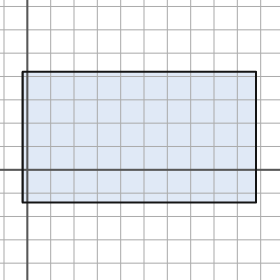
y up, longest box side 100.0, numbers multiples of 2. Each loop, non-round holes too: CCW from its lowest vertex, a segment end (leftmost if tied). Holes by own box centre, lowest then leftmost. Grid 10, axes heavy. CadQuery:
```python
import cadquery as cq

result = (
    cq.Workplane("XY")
    .moveTo(-2.0, -14.0)
    .lineTo(98.0, -14.0)
    .lineTo(98.0, 42.0)
    .lineTo(-2.0, 42.0)
    .close()
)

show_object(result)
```